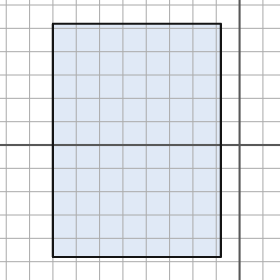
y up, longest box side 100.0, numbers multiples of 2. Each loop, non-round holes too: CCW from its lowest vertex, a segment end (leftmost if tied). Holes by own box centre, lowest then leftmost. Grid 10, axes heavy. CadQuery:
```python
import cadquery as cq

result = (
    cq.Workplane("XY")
    .moveTo(-80.0, -48.0)
    .lineTo(-8.0, -48.0)
    .lineTo(-8.0, 52.0)
    .lineTo(-80.0, 52.0)
    .close()
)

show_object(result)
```